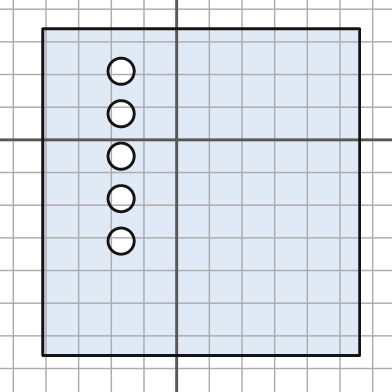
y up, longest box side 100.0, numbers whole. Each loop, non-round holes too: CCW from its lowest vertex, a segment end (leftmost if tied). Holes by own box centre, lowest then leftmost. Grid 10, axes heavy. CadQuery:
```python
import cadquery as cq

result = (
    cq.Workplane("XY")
    .moveTo(-41.0, -66.0)
    .lineTo(56.0, -66.0)
    .lineTo(56.0, 34.0)
    .lineTo(-41.0, 34.0)
    .close()
    .moveTo(-17.0, -31.0)
    .circle(4.0)
    .moveTo(-17.0, -18.0)
    .circle(4.0)
    .moveTo(-17.0, -5.0)
    .circle(4.0)
    .moveTo(-17.0, 8.0)
    .circle(4.0)
    .moveTo(-17.0, 21.0)
    .circle(4.0)
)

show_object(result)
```